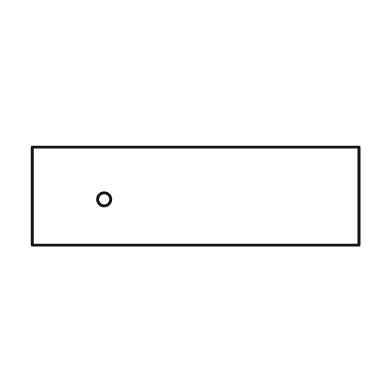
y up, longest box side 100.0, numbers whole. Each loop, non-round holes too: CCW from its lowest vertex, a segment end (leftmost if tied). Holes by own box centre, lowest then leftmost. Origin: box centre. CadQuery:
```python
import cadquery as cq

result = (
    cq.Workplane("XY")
    .moveTo(-50.0, -15.0)
    .lineTo(50.0, -15.0)
    .lineTo(50.0, 15.0)
    .lineTo(-50.0, 15.0)
    .close()
    .moveTo(-28.0, -1.0)
    .circle(2.0)
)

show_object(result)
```